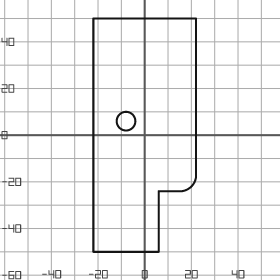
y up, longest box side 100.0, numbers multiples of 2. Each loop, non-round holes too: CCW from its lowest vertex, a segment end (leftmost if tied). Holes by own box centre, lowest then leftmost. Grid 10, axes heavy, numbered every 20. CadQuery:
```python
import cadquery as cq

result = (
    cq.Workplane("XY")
    .moveTo(-22.0, -50.0)
    .lineTo(6.0, -50.0)
    .lineTo(6.0, -24.0)
    .lineTo(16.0, -24.0)
    .threePointArc((20.0, -22.0), (22.0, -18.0))
    .lineTo(22.0, 50.0)
    .lineTo(-22.0, 50.0)
    .close()
    .moveTo(-8.0, 6.0)
    .circle(4.0)
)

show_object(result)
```